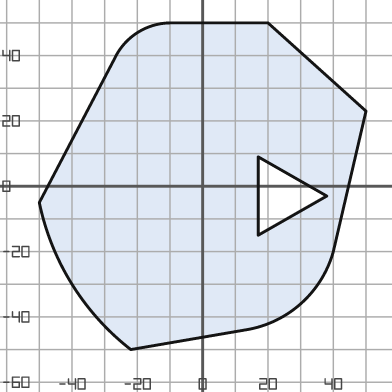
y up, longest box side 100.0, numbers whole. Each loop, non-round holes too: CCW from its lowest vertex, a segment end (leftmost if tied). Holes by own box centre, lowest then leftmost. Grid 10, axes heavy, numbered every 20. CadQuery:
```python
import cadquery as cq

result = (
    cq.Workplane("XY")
    .moveTo(-22.0, -50.0)
    .lineTo(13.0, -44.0)
    .threePointArc((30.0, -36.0), (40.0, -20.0))
    .lineTo(50.0, 23.0)
    .lineTo(20.0, 50.0)
    .lineTo(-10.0, 50.0)
    .threePointArc((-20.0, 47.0), (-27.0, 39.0))
    .lineTo(-50.0, -5.0)
    .threePointArc((-40.0, -30.0), (-22.0, -50.0))
    .close()
    .moveTo(17.0, -15.0)
    .lineTo(38.0, -3.0)
    .lineTo(17.0, 9.0)
    .close()
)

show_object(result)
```